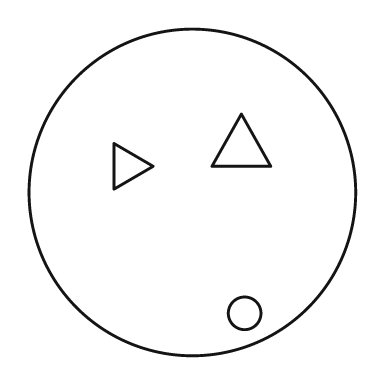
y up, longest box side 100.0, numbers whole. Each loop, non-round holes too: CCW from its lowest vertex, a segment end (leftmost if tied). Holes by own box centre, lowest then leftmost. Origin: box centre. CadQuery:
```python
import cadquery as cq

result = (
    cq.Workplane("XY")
    .moveTo(0.0, 0.0)
    .circle(50.0)
    .moveTo(16.0, -37.0)
    .circle(5.0)
    .moveTo(-24.0, 1.0)
    .lineTo(-12.0, 8.0)
    .lineTo(-24.0, 15.0)
    .close()
    .moveTo(6.0, 8.0)
    .lineTo(24.0, 8.0)
    .lineTo(15.0, 24.0)
    .close()
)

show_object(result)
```